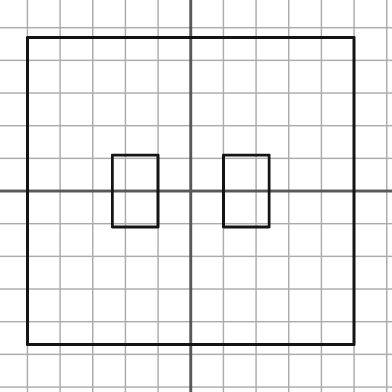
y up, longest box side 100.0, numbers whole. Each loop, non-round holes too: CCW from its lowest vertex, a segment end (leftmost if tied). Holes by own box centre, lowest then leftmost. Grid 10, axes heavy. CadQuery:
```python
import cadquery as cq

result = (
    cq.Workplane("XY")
    .moveTo(-50.0, -47.0)
    .lineTo(50.0, -47.0)
    .lineTo(50.0, 47.0)
    .lineTo(-50.0, 47.0)
    .close()
    .moveTo(-24.0, -11.0)
    .lineTo(-10.0, -11.0)
    .lineTo(-10.0, 11.0)
    .lineTo(-24.0, 11.0)
    .close()
    .moveTo(10.0, -11.0)
    .lineTo(24.0, -11.0)
    .lineTo(24.0, 11.0)
    .lineTo(10.0, 11.0)
    .close()
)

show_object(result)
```